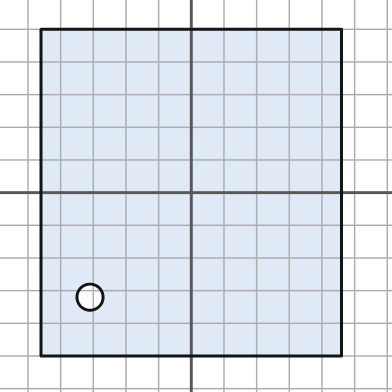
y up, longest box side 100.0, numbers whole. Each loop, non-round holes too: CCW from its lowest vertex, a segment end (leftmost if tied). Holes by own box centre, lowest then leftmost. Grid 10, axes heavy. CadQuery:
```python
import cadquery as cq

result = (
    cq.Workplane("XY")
    .moveTo(-46.0, -50.0)
    .lineTo(46.0, -50.0)
    .lineTo(46.0, 50.0)
    .lineTo(-46.0, 50.0)
    .close()
    .moveTo(-31.0, -32.0)
    .circle(4.0)
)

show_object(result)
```